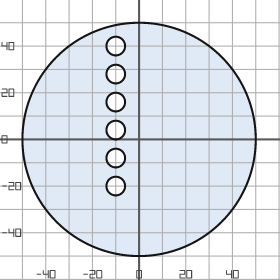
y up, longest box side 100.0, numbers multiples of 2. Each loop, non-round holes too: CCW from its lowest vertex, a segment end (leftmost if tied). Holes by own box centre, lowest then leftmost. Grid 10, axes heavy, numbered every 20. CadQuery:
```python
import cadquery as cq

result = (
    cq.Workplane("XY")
    .moveTo(0.0, 0.0)
    .circle(50.0)
    .moveTo(-10.0, -20.0)
    .circle(4.0)
    .moveTo(-10.0, -8.0)
    .circle(4.0)
    .moveTo(-10.0, 4.0)
    .circle(4.0)
    .moveTo(-10.0, 16.0)
    .circle(4.0)
    .moveTo(-10.0, 28.0)
    .circle(4.0)
    .moveTo(-10.0, 40.0)
    .circle(4.0)
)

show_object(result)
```